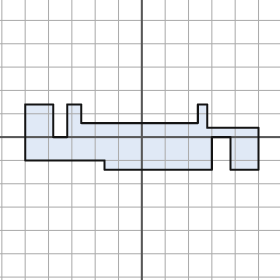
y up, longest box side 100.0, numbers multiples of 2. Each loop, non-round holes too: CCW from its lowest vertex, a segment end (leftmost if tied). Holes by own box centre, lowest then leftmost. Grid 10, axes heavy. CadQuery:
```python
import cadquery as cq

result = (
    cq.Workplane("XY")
    .moveTo(-16.0, -14.0)
    .lineTo(30.0, -14.0)
    .lineTo(30.0, 0.0)
    .lineTo(38.0, 0.0)
    .lineTo(38.0, -14.0)
    .lineTo(50.0, -14.0)
    .lineTo(50.0, 4.0)
    .lineTo(28.0, 4.0)
    .lineTo(28.0, 14.0)
    .lineTo(24.0, 14.0)
    .lineTo(24.0, 6.0)
    .lineTo(-26.0, 6.0)
    .lineTo(-26.0, 14.0)
    .lineTo(-32.0, 14.0)
    .lineTo(-32.0, 0.0)
    .lineTo(-38.0, 0.0)
    .lineTo(-38.0, 14.0)
    .lineTo(-50.0, 14.0)
    .lineTo(-50.0, -10.0)
    .lineTo(-16.0, -10.0)
    .close()
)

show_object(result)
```